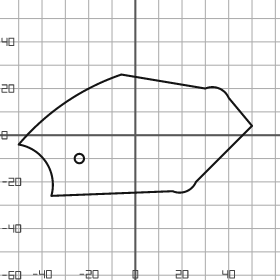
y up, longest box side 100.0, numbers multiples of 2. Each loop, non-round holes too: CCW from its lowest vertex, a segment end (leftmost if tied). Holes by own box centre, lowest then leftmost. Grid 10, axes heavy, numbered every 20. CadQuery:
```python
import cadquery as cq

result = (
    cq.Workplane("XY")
    .moveTo(-36.0, -26.0)
    .lineTo(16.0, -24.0)
    .threePointArc((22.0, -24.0), (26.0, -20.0))
    .lineTo(50.0, 4.0)
    .lineTo(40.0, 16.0)
    .threePointArc((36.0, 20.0), (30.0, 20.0))
    .lineTo(-6.0, 26.0)
    .threePointArc((-30.0, 14.0), (-50.0, -4.0))
    .threePointArc((-38.0, -12.0), (-36.0, -26.0))
    .close()
    .moveTo(-24.0, -10.0)
    .circle(2.0)
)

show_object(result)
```